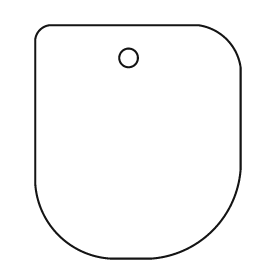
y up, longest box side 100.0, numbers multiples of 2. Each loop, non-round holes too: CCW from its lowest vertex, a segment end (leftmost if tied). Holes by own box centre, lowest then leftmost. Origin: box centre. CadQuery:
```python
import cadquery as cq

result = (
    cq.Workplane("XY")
    .moveTo(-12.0, -50.0)
    .lineTo(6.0, -50.0)
    .threePointArc((32.0, -38.0), (44.0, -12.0))
    .lineTo(44.0, 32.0)
    .threePointArc((38.0, 44.0), (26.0, 50.0))
    .lineTo(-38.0, 50.0)
    .threePointArc((-42.0, 48.0), (-44.0, 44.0))
    .lineTo(-44.0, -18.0)
    .threePointArc((-34.0, -40.0), (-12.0, -50.0))
    .close()
    .moveTo(-4.0, 36.0)
    .circle(4.0)
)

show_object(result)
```